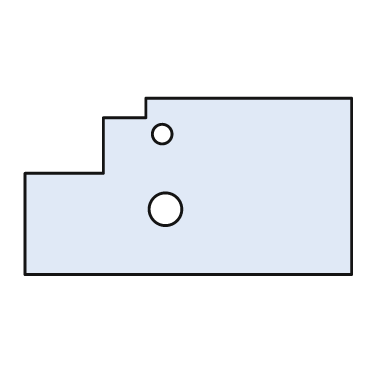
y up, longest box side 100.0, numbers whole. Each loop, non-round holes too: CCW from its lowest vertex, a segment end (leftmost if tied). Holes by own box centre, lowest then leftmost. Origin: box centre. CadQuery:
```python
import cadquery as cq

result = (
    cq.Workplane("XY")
    .moveTo(-50.0, -27.0)
    .lineTo(50.0, -27.0)
    .lineTo(50.0, 27.0)
    .lineTo(-13.0, 27.0)
    .lineTo(-13.0, 21.0)
    .lineTo(-26.0, 21.0)
    .lineTo(-26.0, 4.0)
    .lineTo(-50.0, 4.0)
    .close()
    .moveTo(-7.0, -7.0)
    .circle(5.0)
    .moveTo(-8.0, 16.0)
    .circle(3.0)
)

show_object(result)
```